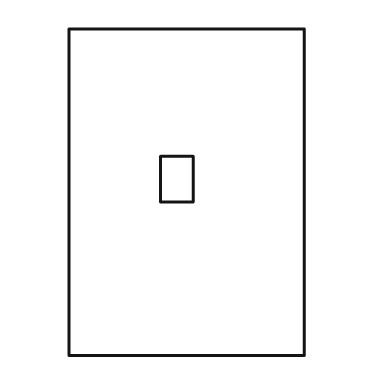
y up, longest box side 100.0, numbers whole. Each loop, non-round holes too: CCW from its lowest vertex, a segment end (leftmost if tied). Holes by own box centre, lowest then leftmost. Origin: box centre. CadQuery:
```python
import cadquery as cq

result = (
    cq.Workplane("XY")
    .moveTo(-36.0, -50.0)
    .lineTo(36.0, -50.0)
    .lineTo(36.0, 50.0)
    .lineTo(-36.0, 50.0)
    .close()
    .moveTo(-8.0, -3.0)
    .lineTo(2.0, -3.0)
    .lineTo(2.0, 11.0)
    .lineTo(-8.0, 11.0)
    .close()
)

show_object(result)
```